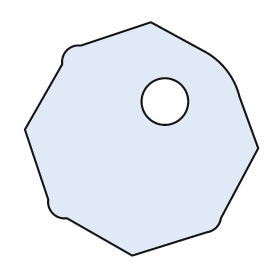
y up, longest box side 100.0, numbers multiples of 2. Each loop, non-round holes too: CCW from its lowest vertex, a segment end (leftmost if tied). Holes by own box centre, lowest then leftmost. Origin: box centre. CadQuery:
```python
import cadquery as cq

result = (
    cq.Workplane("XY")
    .moveTo(-4.0, -50.0)
    .lineTo(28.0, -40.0)
    .threePointArc((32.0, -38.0), (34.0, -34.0))
    .lineTo(50.0, -4.0)
    .lineTo(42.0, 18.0)
    .threePointArc((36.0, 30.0), (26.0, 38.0))
    .lineTo(4.0, 50.0)
    .lineTo(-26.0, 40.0)
    .threePointArc((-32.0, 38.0), (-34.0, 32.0))
    .lineTo(-50.0, 4.0)
    .lineTo(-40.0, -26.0)
    .threePointArc((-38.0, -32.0), (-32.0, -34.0))
    .close()
    .moveTo(10.0, 16.0)
    .circle(10.0)
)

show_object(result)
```